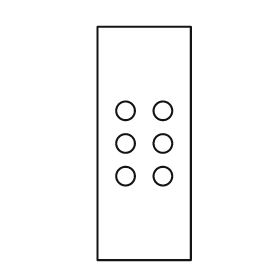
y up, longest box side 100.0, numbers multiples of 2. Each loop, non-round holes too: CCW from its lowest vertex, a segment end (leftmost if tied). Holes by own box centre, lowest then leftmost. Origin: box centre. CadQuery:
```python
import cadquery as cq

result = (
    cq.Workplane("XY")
    .moveTo(-20.0, -50.0)
    .lineTo(20.0, -50.0)
    .lineTo(20.0, 50.0)
    .lineTo(-20.0, 50.0)
    .close()
    .moveTo(-8.0, -14.0)
    .circle(4.0)
    .moveTo(8.0, -14.0)
    .circle(4.0)
    .moveTo(-8.0, 0.0)
    .circle(4.0)
    .moveTo(8.0, 0.0)
    .circle(4.0)
    .moveTo(-8.0, 14.0)
    .circle(4.0)
    .moveTo(8.0, 14.0)
    .circle(4.0)
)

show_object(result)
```